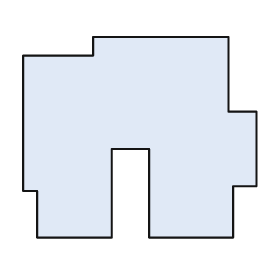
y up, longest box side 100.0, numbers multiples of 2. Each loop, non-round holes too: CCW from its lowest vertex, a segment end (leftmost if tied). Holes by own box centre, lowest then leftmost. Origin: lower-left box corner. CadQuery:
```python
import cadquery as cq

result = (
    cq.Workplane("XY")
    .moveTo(6.0, 0.0)
    .lineTo(38.0, 0.0)
    .lineTo(38.0, 38.0)
    .lineTo(54.0, 38.0)
    .lineTo(54.0, 0.0)
    .lineTo(90.0, 0.0)
    .lineTo(90.0, 22.0)
    .lineTo(100.0, 22.0)
    .lineTo(100.0, 54.0)
    .lineTo(88.0, 54.0)
    .lineTo(88.0, 86.0)
    .lineTo(30.0, 86.0)
    .lineTo(30.0, 78.0)
    .lineTo(0.0, 78.0)
    .lineTo(0.0, 20.0)
    .lineTo(6.0, 20.0)
    .close()
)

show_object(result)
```